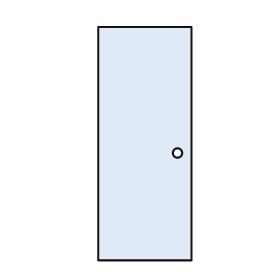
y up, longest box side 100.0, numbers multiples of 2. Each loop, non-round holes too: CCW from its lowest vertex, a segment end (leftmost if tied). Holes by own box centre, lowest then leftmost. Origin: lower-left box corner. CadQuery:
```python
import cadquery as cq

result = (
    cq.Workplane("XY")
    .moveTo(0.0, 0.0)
    .lineTo(40.0, 0.0)
    .lineTo(40.0, 100.0)
    .lineTo(0.0, 100.0)
    .close()
    .moveTo(34.0, 46.0)
    .circle(2.0)
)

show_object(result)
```